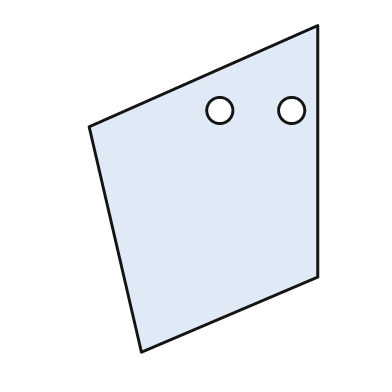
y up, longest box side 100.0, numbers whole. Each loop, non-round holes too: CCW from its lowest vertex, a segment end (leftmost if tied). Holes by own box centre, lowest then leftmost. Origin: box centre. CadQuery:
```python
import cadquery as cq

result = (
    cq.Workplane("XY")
    .moveTo(-19.0, -50.0)
    .lineTo(35.0, -27.0)
    .lineTo(35.0, 50.0)
    .lineTo(-35.0, 19.0)
    .close()
    .moveTo(5.0, 24.0)
    .circle(4.0)
    .moveTo(27.0, 24.0)
    .circle(4.0)
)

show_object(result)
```